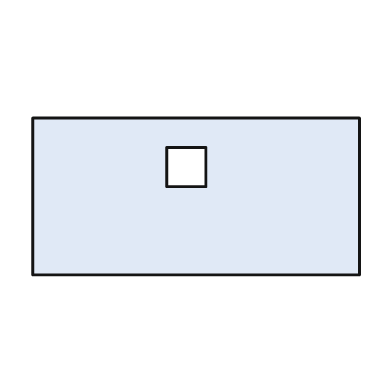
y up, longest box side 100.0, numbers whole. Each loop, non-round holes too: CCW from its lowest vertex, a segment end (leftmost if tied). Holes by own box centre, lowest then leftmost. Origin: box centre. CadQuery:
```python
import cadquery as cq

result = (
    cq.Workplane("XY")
    .moveTo(-50.0, -24.0)
    .lineTo(50.0, -24.0)
    .lineTo(50.0, 24.0)
    .lineTo(-50.0, 24.0)
    .close()
    .moveTo(-9.0, 3.0)
    .lineTo(3.0, 3.0)
    .lineTo(3.0, 15.0)
    .lineTo(-9.0, 15.0)
    .close()
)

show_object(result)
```